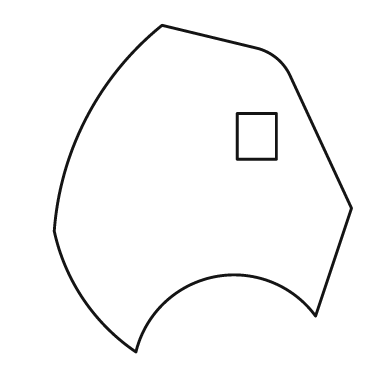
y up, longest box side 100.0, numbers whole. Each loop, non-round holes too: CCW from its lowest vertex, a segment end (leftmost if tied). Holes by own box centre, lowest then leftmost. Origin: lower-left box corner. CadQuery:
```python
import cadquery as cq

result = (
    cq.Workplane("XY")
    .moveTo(25.0, 0.0)
    .threePointArc((49.0, 23.0), (80.0, 11.0))
    .lineTo(91.0, 44.0)
    .lineTo(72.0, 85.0)
    .threePointArc((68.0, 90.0), (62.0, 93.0))
    .lineTo(33.0, 100.0)
    .threePointArc((10.0, 72.0), (0.0, 37.0))
    .threePointArc((9.0, 16.0), (25.0, 0.0))
    .close()
    .moveTo(56.0, 59.0)
    .lineTo(68.0, 59.0)
    .lineTo(68.0, 73.0)
    .lineTo(56.0, 73.0)
    .close()
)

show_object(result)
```